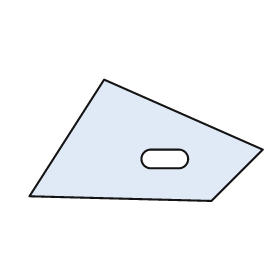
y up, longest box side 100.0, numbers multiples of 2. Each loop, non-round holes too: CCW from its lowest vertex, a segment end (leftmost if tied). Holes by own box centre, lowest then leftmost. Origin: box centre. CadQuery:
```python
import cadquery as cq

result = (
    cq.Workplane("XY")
    .moveTo(28.0, -26.0)
    .lineTo(50.0, -4.0)
    .lineTo(-18.0, 26.0)
    .lineTo(-50.0, -24.0)
    .close()
    .moveTo(2.0, -12.0)
    .lineTo(14.0, -12.0)
    .threePointArc((18.0, -8.0), (14.0, -4.0))
    .lineTo(2.0, -4.0)
    .threePointArc((-2.0, -8.0), (2.0, -12.0))
    .close()
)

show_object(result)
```